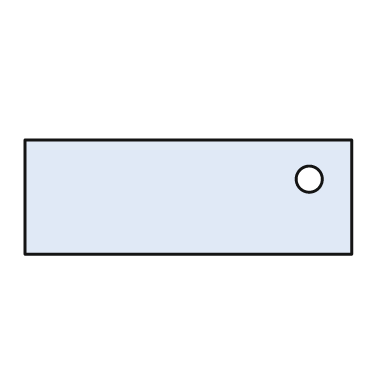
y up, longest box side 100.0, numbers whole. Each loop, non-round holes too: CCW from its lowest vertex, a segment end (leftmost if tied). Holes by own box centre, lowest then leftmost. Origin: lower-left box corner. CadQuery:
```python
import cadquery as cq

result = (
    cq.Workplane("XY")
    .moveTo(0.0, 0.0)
    .lineTo(100.0, 0.0)
    .lineTo(100.0, 35.0)
    .lineTo(0.0, 35.0)
    .close()
    .moveTo(87.0, 23.0)
    .circle(4.0)
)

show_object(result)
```